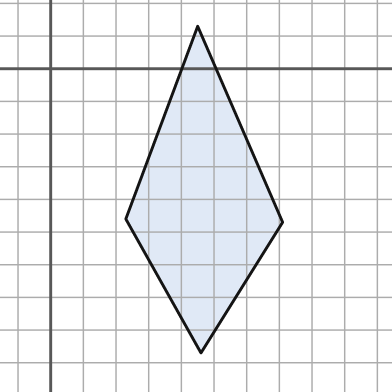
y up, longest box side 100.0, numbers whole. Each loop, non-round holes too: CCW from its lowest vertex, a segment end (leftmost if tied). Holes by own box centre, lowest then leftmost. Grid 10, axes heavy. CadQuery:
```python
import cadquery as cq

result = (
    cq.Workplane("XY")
    .moveTo(46.0, -87.0)
    .lineTo(71.0, -47.0)
    .lineTo(45.0, 13.0)
    .lineTo(23.0, -46.0)
    .close()
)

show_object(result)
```